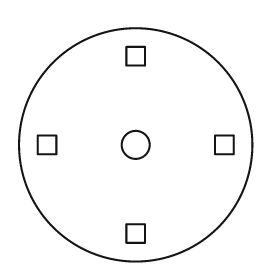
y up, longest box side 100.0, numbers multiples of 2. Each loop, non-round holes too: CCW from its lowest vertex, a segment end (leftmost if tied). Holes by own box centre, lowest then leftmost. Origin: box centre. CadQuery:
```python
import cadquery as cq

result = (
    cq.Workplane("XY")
    .moveTo(0.0, 0.0)
    .circle(50.0)
    .moveTo(-4.0, -42.0)
    .lineTo(4.0, -42.0)
    .lineTo(4.0, -34.0)
    .lineTo(-4.0, -34.0)
    .close()
    .moveTo(-42.0, -4.0)
    .lineTo(-34.0, -4.0)
    .lineTo(-34.0, 4.0)
    .lineTo(-42.0, 4.0)
    .close()
    .moveTo(0.0, 0.0)
    .circle(6.0)
    .moveTo(34.0, -4.0)
    .lineTo(42.0, -4.0)
    .lineTo(42.0, 4.0)
    .lineTo(34.0, 4.0)
    .close()
    .moveTo(-4.0, 34.0)
    .lineTo(4.0, 34.0)
    .lineTo(4.0, 42.0)
    .lineTo(-4.0, 42.0)
    .close()
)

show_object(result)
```